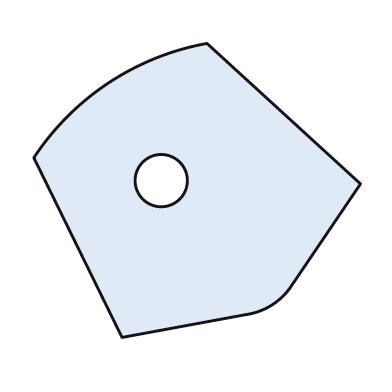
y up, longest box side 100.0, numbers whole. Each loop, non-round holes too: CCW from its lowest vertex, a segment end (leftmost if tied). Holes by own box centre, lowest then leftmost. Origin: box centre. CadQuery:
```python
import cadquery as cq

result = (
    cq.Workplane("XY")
    .moveTo(-23.0, -45.0)
    .lineTo(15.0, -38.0)
    .threePointArc((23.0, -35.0), (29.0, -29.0))
    .lineTo(50.0, 2.0)
    .lineTo(3.0, 45.0)
    .threePointArc((-27.0, 33.0), (-50.0, 10.0))
    .close()
    .moveTo(-11.0, 3.0)
    .circle(8.0)
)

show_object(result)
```